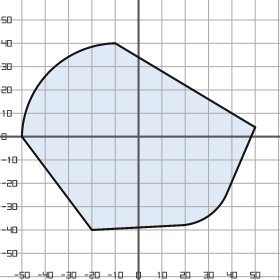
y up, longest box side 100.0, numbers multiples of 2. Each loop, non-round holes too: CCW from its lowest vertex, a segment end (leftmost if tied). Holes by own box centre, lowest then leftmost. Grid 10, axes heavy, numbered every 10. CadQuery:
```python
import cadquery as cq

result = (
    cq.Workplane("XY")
    .moveTo(-20.0, -40.0)
    .lineTo(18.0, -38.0)
    .threePointArc((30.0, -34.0), (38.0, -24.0))
    .lineTo(50.0, 4.0)
    .lineTo(-10.0, 40.0)
    .threePointArc((-38.0, 28.0), (-50.0, 0.0))
    .close()
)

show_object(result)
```